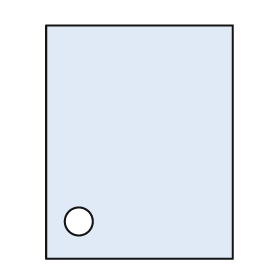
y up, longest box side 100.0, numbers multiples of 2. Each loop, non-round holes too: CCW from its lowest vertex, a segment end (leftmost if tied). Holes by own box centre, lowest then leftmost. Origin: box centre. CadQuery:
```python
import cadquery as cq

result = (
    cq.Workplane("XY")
    .moveTo(-40.0, -50.0)
    .lineTo(40.0, -50.0)
    .lineTo(40.0, 50.0)
    .lineTo(-40.0, 50.0)
    .close()
    .moveTo(-26.0, -34.0)
    .circle(6.0)
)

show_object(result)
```